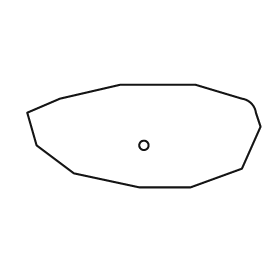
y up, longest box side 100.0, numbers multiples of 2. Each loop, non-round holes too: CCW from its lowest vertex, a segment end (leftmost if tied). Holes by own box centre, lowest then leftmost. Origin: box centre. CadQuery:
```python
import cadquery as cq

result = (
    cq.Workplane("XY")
    .moveTo(-2.0, -22.0)
    .lineTo(20.0, -22.0)
    .lineTo(42.0, -14.0)
    .lineTo(50.0, 4.0)
    .lineTo(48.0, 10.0)
    .threePointArc((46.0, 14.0), (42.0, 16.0))
    .lineTo(22.0, 22.0)
    .lineTo(-10.0, 22.0)
    .lineTo(-36.0, 16.0)
    .lineTo(-50.0, 10.0)
    .lineTo(-46.0, -4.0)
    .lineTo(-30.0, -16.0)
    .close()
    .moveTo(0.0, -4.0)
    .circle(2.0)
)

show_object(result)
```